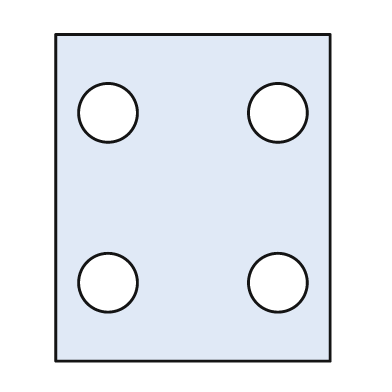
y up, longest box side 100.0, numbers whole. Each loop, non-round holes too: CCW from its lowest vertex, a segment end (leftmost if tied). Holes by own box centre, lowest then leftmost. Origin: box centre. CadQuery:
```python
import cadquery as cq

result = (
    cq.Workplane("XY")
    .moveTo(-42.0, -50.0)
    .lineTo(42.0, -50.0)
    .lineTo(42.0, 50.0)
    .lineTo(-42.0, 50.0)
    .close()
    .moveTo(-26.0, -26.0)
    .circle(9.0)
    .moveTo(26.0, -26.0)
    .circle(9.0)
    .moveTo(-26.0, 26.0)
    .circle(9.0)
    .moveTo(26.0, 26.0)
    .circle(9.0)
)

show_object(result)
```